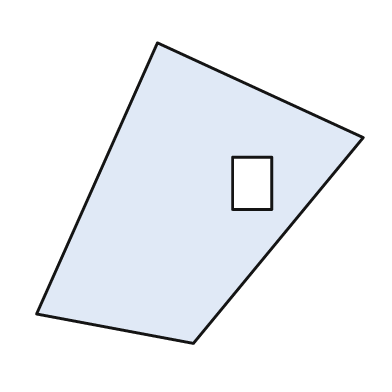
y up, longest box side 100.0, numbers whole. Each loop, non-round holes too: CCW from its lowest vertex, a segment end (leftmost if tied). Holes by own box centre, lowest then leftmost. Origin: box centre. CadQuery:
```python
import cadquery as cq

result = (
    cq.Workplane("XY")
    .moveTo(-2.0, -46.0)
    .lineTo(50.0, 17.0)
    .lineTo(-13.0, 46.0)
    .lineTo(-50.0, -37.0)
    .close()
    .moveTo(10.0, -5.0)
    .lineTo(22.0, -5.0)
    .lineTo(22.0, 11.0)
    .lineTo(10.0, 11.0)
    .close()
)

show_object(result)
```